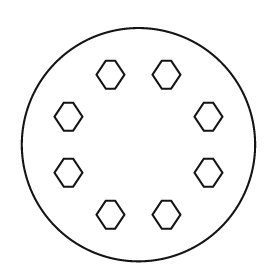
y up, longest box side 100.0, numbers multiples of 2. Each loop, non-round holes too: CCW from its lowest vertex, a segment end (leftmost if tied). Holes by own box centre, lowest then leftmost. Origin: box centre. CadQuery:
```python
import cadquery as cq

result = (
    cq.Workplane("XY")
    .moveTo(0.0, 0.0)
    .circle(50.0)
    .moveTo(-14.0, -36.0)
    .lineTo(-10.0, -36.0)
    .lineTo(-6.0, -30.0)
    .lineTo(-10.0, -24.0)
    .lineTo(-14.0, -24.0)
    .lineTo(-18.0, -30.0)
    .close()
    .moveTo(10.0, -36.0)
    .lineTo(14.0, -36.0)
    .lineTo(18.0, -30.0)
    .lineTo(14.0, -24.0)
    .lineTo(10.0, -24.0)
    .lineTo(6.0, -30.0)
    .close()
    .moveTo(-32.0, -18.0)
    .lineTo(-28.0, -18.0)
    .lineTo(-24.0, -12.0)
    .lineTo(-28.0, -6.0)
    .lineTo(-32.0, -6.0)
    .lineTo(-36.0, -12.0)
    .close()
    .moveTo(28.0, -18.0)
    .lineTo(32.0, -18.0)
    .lineTo(36.0, -12.0)
    .lineTo(32.0, -6.0)
    .lineTo(28.0, -6.0)
    .lineTo(24.0, -12.0)
    .close()
    .moveTo(-32.0, 6.0)
    .lineTo(-28.0, 6.0)
    .lineTo(-24.0, 12.0)
    .lineTo(-28.0, 18.0)
    .lineTo(-32.0, 18.0)
    .lineTo(-36.0, 12.0)
    .close()
    .moveTo(28.0, 6.0)
    .lineTo(32.0, 6.0)
    .lineTo(36.0, 12.0)
    .lineTo(32.0, 18.0)
    .lineTo(28.0, 18.0)
    .lineTo(24.0, 12.0)
    .close()
    .moveTo(-14.0, 24.0)
    .lineTo(-10.0, 24.0)
    .lineTo(-6.0, 30.0)
    .lineTo(-10.0, 36.0)
    .lineTo(-14.0, 36.0)
    .lineTo(-18.0, 30.0)
    .close()
    .moveTo(10.0, 24.0)
    .lineTo(14.0, 24.0)
    .lineTo(18.0, 30.0)
    .lineTo(14.0, 36.0)
    .lineTo(10.0, 36.0)
    .lineTo(6.0, 30.0)
    .close()
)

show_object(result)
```